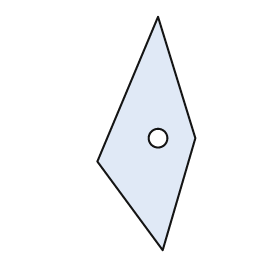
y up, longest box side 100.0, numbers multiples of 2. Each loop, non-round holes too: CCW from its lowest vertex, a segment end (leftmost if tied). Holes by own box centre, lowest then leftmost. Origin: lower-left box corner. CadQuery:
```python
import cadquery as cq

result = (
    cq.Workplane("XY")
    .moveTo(28.0, 0.0)
    .lineTo(42.0, 48.0)
    .lineTo(26.0, 100.0)
    .lineTo(0.0, 38.0)
    .close()
    .moveTo(26.0, 48.0)
    .circle(4.0)
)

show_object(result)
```